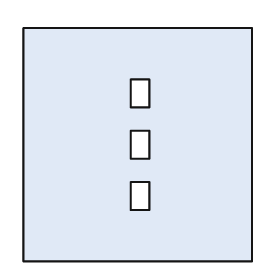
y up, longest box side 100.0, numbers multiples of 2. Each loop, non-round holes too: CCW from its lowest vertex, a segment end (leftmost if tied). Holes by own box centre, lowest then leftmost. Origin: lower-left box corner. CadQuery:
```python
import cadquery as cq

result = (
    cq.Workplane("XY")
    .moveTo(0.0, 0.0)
    .lineTo(98.0, 0.0)
    .lineTo(98.0, 100.0)
    .lineTo(0.0, 100.0)
    .close()
    .moveTo(46.0, 22.0)
    .lineTo(54.0, 22.0)
    .lineTo(54.0, 34.0)
    .lineTo(46.0, 34.0)
    .close()
    .moveTo(46.0, 44.0)
    .lineTo(54.0, 44.0)
    .lineTo(54.0, 56.0)
    .lineTo(46.0, 56.0)
    .close()
    .moveTo(46.0, 66.0)
    .lineTo(54.0, 66.0)
    .lineTo(54.0, 78.0)
    .lineTo(46.0, 78.0)
    .close()
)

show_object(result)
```